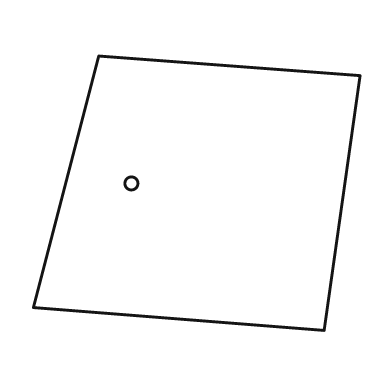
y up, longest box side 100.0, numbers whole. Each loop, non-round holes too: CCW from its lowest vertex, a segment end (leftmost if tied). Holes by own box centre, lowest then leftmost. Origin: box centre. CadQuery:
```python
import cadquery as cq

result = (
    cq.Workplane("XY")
    .moveTo(39.0, -42.0)
    .lineTo(50.0, 36.0)
    .lineTo(-30.0, 42.0)
    .lineTo(-50.0, -35.0)
    .close()
    .moveTo(-20.0, 3.0)
    .circle(2.0)
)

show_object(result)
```